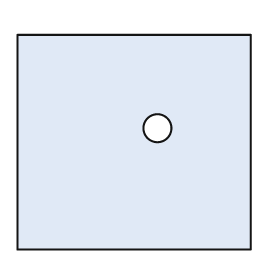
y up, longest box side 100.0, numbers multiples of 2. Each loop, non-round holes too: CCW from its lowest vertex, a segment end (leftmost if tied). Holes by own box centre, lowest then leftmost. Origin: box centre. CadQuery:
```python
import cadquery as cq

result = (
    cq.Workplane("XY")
    .moveTo(-50.0, -46.0)
    .lineTo(50.0, -46.0)
    .lineTo(50.0, 46.0)
    .lineTo(-50.0, 46.0)
    .close()
    .moveTo(10.0, 6.0)
    .circle(6.0)
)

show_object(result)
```